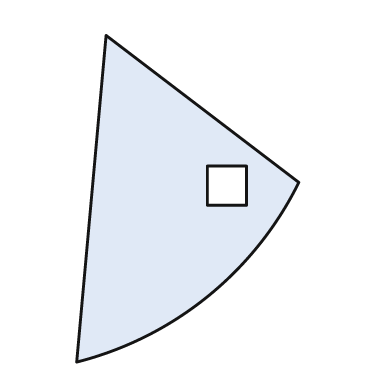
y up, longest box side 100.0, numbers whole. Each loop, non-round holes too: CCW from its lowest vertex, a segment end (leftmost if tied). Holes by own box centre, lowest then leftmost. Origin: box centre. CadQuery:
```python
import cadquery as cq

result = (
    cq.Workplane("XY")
    .moveTo(-34.0, -50.0)
    .threePointArc((6.0, -30.0), (34.0, 5.0))
    .lineTo(-25.0, 50.0)
    .close()
    .moveTo(6.0, -2.0)
    .lineTo(18.0, -2.0)
    .lineTo(18.0, 10.0)
    .lineTo(6.0, 10.0)
    .close()
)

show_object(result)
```